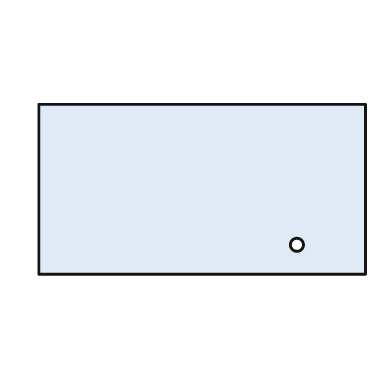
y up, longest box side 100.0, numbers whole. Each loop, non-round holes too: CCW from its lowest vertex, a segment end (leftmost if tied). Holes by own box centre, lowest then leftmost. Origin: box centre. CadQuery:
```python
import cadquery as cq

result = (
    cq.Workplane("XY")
    .moveTo(-50.0, -26.0)
    .lineTo(50.0, -26.0)
    .lineTo(50.0, 26.0)
    .lineTo(-50.0, 26.0)
    .close()
    .moveTo(29.0, -17.0)
    .circle(2.0)
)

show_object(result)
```